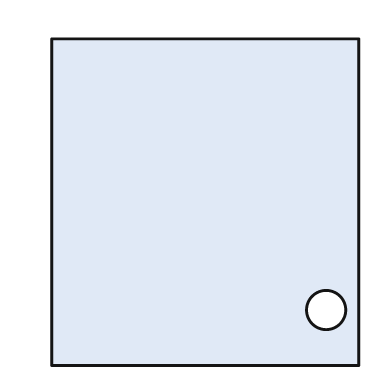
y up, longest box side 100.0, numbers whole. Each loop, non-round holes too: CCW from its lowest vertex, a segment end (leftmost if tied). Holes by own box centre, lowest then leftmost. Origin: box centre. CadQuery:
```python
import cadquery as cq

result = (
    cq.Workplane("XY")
    .moveTo(-47.0, -50.0)
    .lineTo(47.0, -50.0)
    .lineTo(47.0, 50.0)
    .lineTo(-47.0, 50.0)
    .close()
    .moveTo(37.0, -33.0)
    .circle(6.0)
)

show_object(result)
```